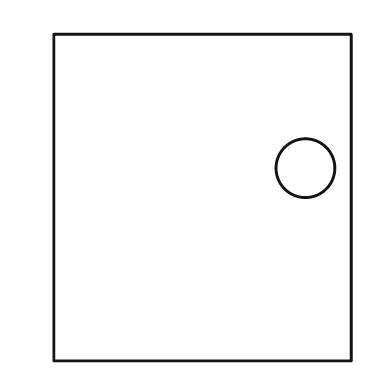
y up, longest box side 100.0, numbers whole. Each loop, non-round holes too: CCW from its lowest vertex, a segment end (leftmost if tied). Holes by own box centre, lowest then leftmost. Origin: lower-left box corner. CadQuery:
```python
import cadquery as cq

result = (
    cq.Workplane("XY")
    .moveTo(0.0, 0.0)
    .lineTo(91.0, 0.0)
    .lineTo(91.0, 100.0)
    .lineTo(0.0, 100.0)
    .close()
    .moveTo(77.0, 59.0)
    .circle(9.0)
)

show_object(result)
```